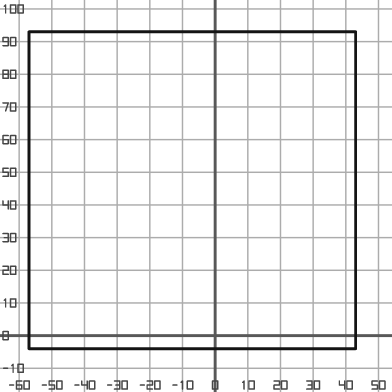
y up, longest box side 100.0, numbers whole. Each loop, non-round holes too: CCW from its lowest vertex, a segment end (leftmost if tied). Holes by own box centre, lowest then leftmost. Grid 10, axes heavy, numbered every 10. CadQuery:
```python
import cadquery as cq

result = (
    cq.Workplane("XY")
    .moveTo(-57.0, -4.0)
    .lineTo(43.0, -4.0)
    .lineTo(43.0, 93.0)
    .lineTo(-57.0, 93.0)
    .close()
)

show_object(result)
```